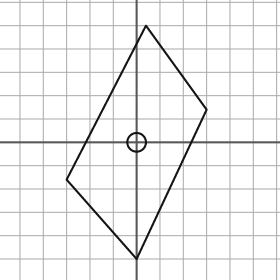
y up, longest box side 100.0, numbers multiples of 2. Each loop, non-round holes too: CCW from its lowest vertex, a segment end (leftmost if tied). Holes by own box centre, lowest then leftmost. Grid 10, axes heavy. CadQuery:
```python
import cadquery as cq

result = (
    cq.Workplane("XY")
    .moveTo(0.0, -50.0)
    .lineTo(30.0, 14.0)
    .lineTo(4.0, 50.0)
    .lineTo(-30.0, -16.0)
    .close()
    .moveTo(0.0, 0.0)
    .circle(4.0)
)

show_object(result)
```